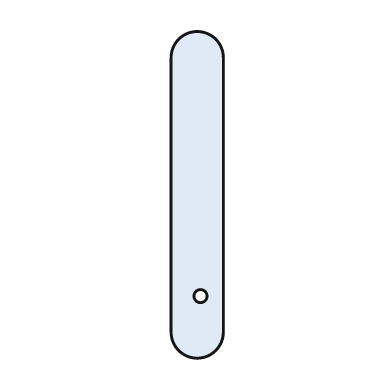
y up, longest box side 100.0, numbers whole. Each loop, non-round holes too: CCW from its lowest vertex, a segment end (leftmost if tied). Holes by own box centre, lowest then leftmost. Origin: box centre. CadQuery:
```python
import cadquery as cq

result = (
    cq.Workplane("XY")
    .moveTo(-8.0, -42.0)
    .threePointArc((0.0, -50.0), (8.0, -42.0))
    .lineTo(8.0, 42.0)
    .threePointArc((0.0, 50.0), (-8.0, 42.0))
    .close()
    .moveTo(1.0, -31.0)
    .circle(2.0)
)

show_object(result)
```